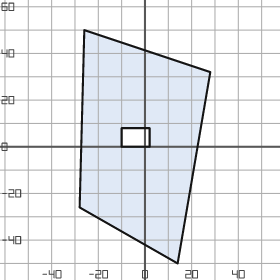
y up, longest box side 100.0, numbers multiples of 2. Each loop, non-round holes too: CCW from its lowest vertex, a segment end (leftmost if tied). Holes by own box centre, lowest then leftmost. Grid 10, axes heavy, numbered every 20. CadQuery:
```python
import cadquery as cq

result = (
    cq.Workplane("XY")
    .moveTo(14.0, -50.0)
    .lineTo(28.0, 32.0)
    .lineTo(-26.0, 50.0)
    .lineTo(-28.0, -26.0)
    .close()
    .moveTo(-10.0, 0.0)
    .lineTo(2.0, 0.0)
    .lineTo(2.0, 8.0)
    .lineTo(-10.0, 8.0)
    .close()
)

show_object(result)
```